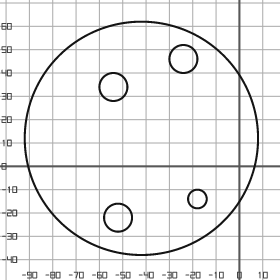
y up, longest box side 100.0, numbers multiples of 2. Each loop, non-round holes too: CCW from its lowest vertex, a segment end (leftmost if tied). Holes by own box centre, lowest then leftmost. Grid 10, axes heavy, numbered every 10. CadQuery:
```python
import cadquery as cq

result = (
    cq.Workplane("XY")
    .moveTo(-42.0, 12.0)
    .circle(50.0)
    .moveTo(-52.0, -22.0)
    .circle(6.0)
    .moveTo(-18.0, -14.0)
    .circle(4.0)
    .moveTo(-54.0, 34.0)
    .circle(6.0)
    .moveTo(-24.0, 46.0)
    .circle(6.0)
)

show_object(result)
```